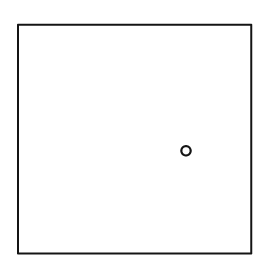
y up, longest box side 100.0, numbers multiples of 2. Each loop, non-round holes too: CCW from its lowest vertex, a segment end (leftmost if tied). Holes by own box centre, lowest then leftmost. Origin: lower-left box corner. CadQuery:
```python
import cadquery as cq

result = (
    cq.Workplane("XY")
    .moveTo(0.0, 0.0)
    .lineTo(100.0, 0.0)
    .lineTo(100.0, 98.0)
    .lineTo(0.0, 98.0)
    .close()
    .moveTo(72.0, 44.0)
    .circle(2.0)
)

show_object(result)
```